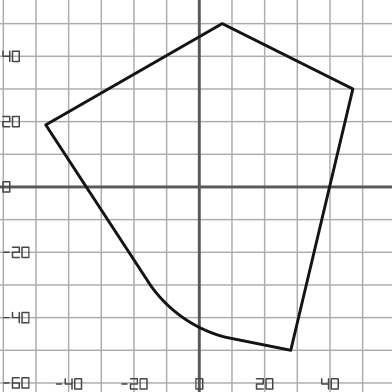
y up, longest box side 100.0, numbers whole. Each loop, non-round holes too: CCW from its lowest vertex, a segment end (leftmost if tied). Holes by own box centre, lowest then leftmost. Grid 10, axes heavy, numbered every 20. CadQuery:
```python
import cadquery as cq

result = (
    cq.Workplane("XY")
    .moveTo(28.0, -50.0)
    .lineTo(47.0, 30.0)
    .lineTo(7.0, 50.0)
    .lineTo(-47.0, 19.0)
    .lineTo(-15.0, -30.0)
    .threePointArc((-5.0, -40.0), (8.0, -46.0))
    .close()
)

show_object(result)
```